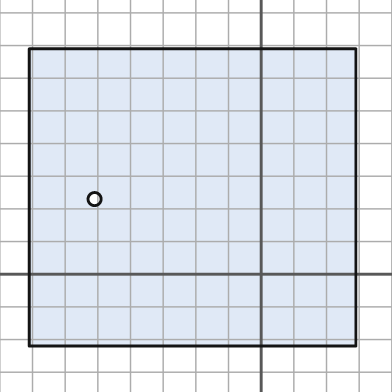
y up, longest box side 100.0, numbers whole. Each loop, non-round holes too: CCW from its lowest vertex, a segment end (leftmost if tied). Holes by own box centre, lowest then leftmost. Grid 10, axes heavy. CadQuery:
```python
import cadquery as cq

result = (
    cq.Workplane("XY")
    .moveTo(-71.0, -22.0)
    .lineTo(29.0, -22.0)
    .lineTo(29.0, 69.0)
    .lineTo(-71.0, 69.0)
    .close()
    .moveTo(-51.0, 23.0)
    .circle(2.0)
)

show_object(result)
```